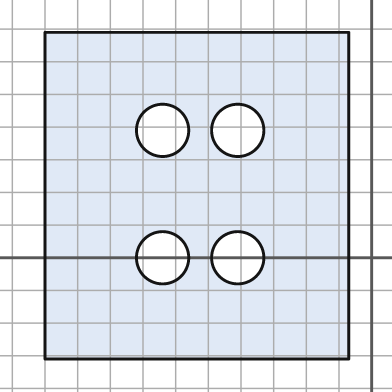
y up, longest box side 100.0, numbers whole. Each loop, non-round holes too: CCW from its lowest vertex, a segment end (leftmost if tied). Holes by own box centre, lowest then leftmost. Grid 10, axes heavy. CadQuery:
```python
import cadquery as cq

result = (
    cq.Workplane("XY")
    .moveTo(-100.0, -31.0)
    .lineTo(-7.0, -31.0)
    .lineTo(-7.0, 69.0)
    .lineTo(-100.0, 69.0)
    .close()
    .moveTo(-64.0, 0.0)
    .circle(8.0)
    .moveTo(-41.0, 0.0)
    .circle(8.0)
    .moveTo(-64.0, 39.0)
    .circle(8.0)
    .moveTo(-41.0, 39.0)
    .circle(8.0)
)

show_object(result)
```